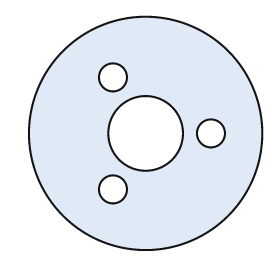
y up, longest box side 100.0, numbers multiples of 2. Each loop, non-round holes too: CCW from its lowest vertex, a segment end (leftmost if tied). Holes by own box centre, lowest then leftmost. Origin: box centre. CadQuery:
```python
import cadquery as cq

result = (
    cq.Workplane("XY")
    .moveTo(0.0, 0.0)
    .circle(50.0)
    .moveTo(-14.0, -24.0)
    .circle(6.0)
    .moveTo(0.0, 0.0)
    .circle(16.0)
    .moveTo(28.0, 0.0)
    .circle(6.0)
    .moveTo(-14.0, 24.0)
    .circle(6.0)
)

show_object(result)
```